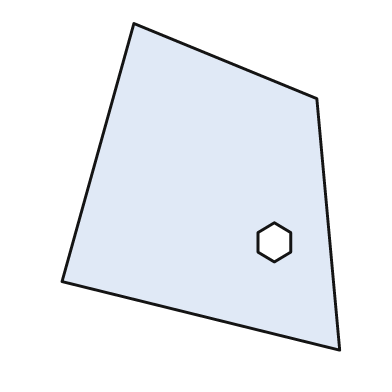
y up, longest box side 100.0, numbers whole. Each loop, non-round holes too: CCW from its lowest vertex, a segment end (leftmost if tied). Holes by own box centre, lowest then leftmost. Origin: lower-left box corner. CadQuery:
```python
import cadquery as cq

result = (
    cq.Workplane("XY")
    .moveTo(85.0, 0.0)
    .lineTo(78.0, 77.0)
    .lineTo(22.0, 100.0)
    .lineTo(0.0, 21.0)
    .close()
    .moveTo(65.0, 27.0)
    .lineTo(70.0, 30.0)
    .lineTo(70.0, 36.0)
    .lineTo(65.0, 39.0)
    .lineTo(60.0, 36.0)
    .lineTo(60.0, 30.0)
    .close()
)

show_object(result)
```